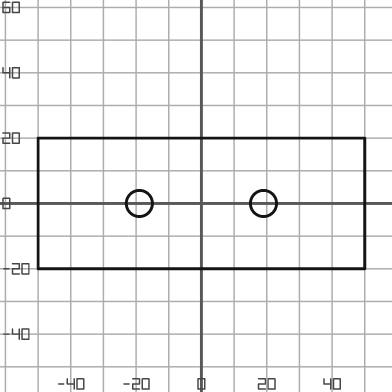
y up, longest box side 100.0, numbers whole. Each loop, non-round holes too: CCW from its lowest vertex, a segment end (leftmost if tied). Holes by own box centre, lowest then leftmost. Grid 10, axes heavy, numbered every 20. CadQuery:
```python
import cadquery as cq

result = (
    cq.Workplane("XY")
    .moveTo(-50.0, -20.0)
    .lineTo(50.0, -20.0)
    .lineTo(50.0, 20.0)
    .lineTo(-50.0, 20.0)
    .close()
    .moveTo(-19.0, 0.0)
    .circle(4.0)
    .moveTo(19.0, 0.0)
    .circle(4.0)
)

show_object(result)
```